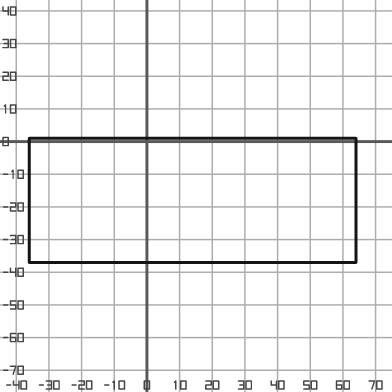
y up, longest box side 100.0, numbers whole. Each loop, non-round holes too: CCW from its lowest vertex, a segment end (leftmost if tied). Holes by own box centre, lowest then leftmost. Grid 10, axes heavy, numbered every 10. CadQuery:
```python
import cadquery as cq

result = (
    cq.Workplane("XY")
    .moveTo(-36.0, -37.0)
    .lineTo(64.0, -37.0)
    .lineTo(64.0, 1.0)
    .lineTo(-36.0, 1.0)
    .close()
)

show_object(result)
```